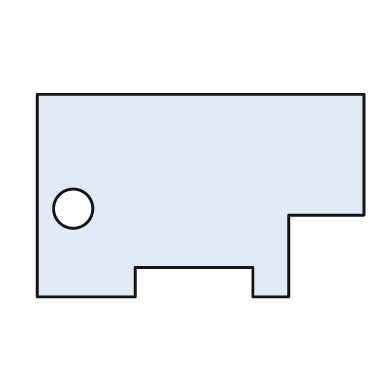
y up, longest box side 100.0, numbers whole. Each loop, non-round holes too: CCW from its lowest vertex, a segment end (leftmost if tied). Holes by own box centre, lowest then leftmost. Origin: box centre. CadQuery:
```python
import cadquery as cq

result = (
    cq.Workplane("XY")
    .moveTo(-50.0, -31.0)
    .lineTo(-20.0, -31.0)
    .lineTo(-20.0, -22.0)
    .lineTo(16.0, -22.0)
    .lineTo(16.0, -31.0)
    .lineTo(27.0, -31.0)
    .lineTo(27.0, -6.0)
    .lineTo(50.0, -6.0)
    .lineTo(50.0, 31.0)
    .lineTo(-50.0, 31.0)
    .close()
    .moveTo(-39.0, -4.0)
    .circle(6.0)
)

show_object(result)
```